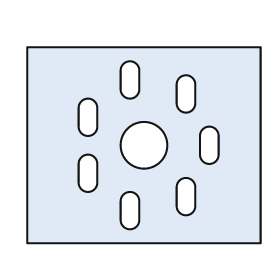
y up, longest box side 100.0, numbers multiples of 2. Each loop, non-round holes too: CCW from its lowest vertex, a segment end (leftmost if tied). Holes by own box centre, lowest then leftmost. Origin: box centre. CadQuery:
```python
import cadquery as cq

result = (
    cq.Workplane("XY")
    .moveTo(-50.0, -42.0)
    .lineTo(50.0, -42.0)
    .lineTo(50.0, 42.0)
    .lineTo(-50.0, 42.0)
    .close()
    .moveTo(-10.0, -32.0)
    .threePointArc((-6.0, -36.0), (-2.0, -32.0))
    .lineTo(-2.0, -24.0)
    .threePointArc((-6.0, -20.0), (-10.0, -24.0))
    .close()
    .moveTo(14.0, -26.0)
    .threePointArc((18.0, -30.0), (22.0, -26.0))
    .lineTo(22.0, -18.0)
    .threePointArc((18.0, -14.0), (14.0, -18.0))
    .close()
    .moveTo(-28.0, -16.0)
    .threePointArc((-24.0, -20.0), (-20.0, -16.0))
    .lineTo(-20.0, -8.0)
    .threePointArc((-24.0, -4.0), (-28.0, -8.0))
    .close()
    .moveTo(0.0, 0.0)
    .circle(10.0)
    .moveTo(24.0, -4.0)
    .threePointArc((28.0, -8.0), (32.0, -4.0))
    .lineTo(32.0, 4.0)
    .threePointArc((28.0, 8.0), (24.0, 4.0))
    .close()
    .moveTo(-28.0, 8.0)
    .threePointArc((-24.0, 4.0), (-20.0, 8.0))
    .lineTo(-20.0, 16.0)
    .threePointArc((-24.0, 20.0), (-28.0, 16.0))
    .close()
    .moveTo(14.0, 18.0)
    .threePointArc((18.0, 14.0), (22.0, 18.0))
    .lineTo(22.0, 26.0)
    .threePointArc((18.0, 30.0), (14.0, 26.0))
    .close()
    .moveTo(-10.0, 24.0)
    .threePointArc((-6.0, 20.0), (-2.0, 24.0))
    .lineTo(-2.0, 32.0)
    .threePointArc((-6.0, 36.0), (-10.0, 32.0))
    .close()
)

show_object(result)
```